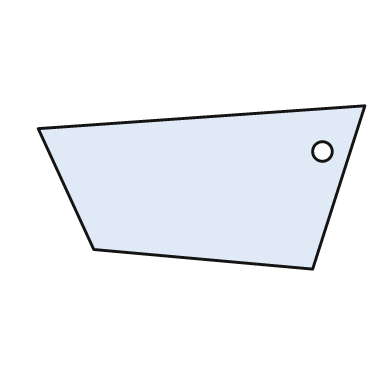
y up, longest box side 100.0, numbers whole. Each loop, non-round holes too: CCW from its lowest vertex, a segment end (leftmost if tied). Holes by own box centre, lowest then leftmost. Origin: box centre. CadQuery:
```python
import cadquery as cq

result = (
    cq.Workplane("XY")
    .moveTo(34.0, -25.0)
    .lineTo(50.0, 25.0)
    .lineTo(-50.0, 18.0)
    .lineTo(-33.0, -19.0)
    .close()
    .moveTo(37.0, 11.0)
    .circle(3.0)
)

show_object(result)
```